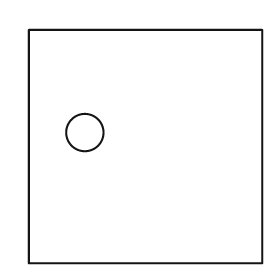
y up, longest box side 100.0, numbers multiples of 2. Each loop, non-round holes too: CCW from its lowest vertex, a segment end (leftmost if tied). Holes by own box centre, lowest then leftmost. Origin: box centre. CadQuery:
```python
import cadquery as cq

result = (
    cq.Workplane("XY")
    .moveTo(-50.0, -50.0)
    .lineTo(50.0, -50.0)
    .lineTo(50.0, 50.0)
    .lineTo(-50.0, 50.0)
    .close()
    .moveTo(-26.0, 6.0)
    .circle(8.0)
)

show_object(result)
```